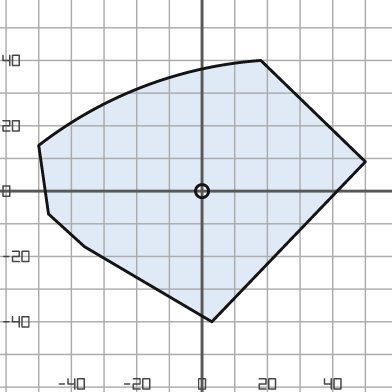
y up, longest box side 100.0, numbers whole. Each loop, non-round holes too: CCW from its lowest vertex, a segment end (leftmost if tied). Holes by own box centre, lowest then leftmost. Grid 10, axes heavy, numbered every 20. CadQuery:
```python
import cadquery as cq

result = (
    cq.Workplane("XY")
    .moveTo(3.0, -40.0)
    .lineTo(50.0, 9.0)
    .lineTo(18.0, 40.0)
    .threePointArc((-18.0, 32.0), (-50.0, 14.0))
    .lineTo(-47.0, -7.0)
    .lineTo(-36.0, -17.0)
    .close()
    .moveTo(0.0, 0.0)
    .circle(2.0)
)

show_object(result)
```